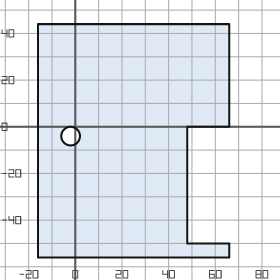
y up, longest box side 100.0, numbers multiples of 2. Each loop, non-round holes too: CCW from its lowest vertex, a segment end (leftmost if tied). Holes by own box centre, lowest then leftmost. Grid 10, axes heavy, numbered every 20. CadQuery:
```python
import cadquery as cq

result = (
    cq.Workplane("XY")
    .moveTo(-16.0, -56.0)
    .lineTo(66.0, -56.0)
    .lineTo(66.0, -50.0)
    .lineTo(48.0, -50.0)
    .lineTo(48.0, 0.0)
    .lineTo(66.0, 0.0)
    .lineTo(66.0, 44.0)
    .lineTo(-16.0, 44.0)
    .close()
    .moveTo(-2.0, -4.0)
    .circle(4.0)
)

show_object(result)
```